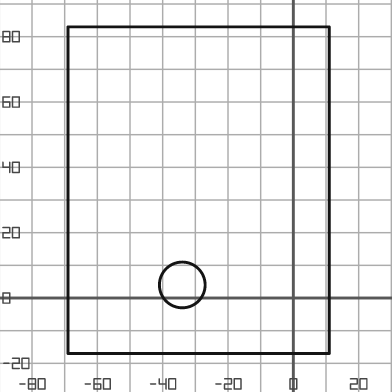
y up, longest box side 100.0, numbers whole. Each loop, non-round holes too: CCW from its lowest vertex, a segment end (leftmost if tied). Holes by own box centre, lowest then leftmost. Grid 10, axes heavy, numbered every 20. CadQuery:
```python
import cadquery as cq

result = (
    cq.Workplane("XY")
    .moveTo(-69.0, -17.0)
    .lineTo(11.0, -17.0)
    .lineTo(11.0, 83.0)
    .lineTo(-69.0, 83.0)
    .close()
    .moveTo(-34.0, 4.0)
    .circle(7.0)
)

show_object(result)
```